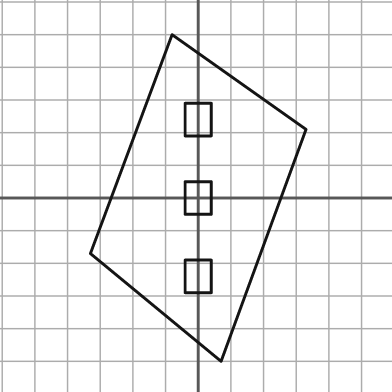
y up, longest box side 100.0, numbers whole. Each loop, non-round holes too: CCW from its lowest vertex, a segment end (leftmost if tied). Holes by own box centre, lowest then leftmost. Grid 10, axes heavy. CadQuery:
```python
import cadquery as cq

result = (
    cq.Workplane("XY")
    .moveTo(7.0, -50.0)
    .lineTo(33.0, 21.0)
    .lineTo(-8.0, 50.0)
    .lineTo(-33.0, -17.0)
    .close()
    .moveTo(-4.0, -29.0)
    .lineTo(4.0, -29.0)
    .lineTo(4.0, -19.0)
    .lineTo(-4.0, -19.0)
    .close()
    .moveTo(-4.0, -5.0)
    .lineTo(4.0, -5.0)
    .lineTo(4.0, 5.0)
    .lineTo(-4.0, 5.0)
    .close()
    .moveTo(-4.0, 19.0)
    .lineTo(4.0, 19.0)
    .lineTo(4.0, 29.0)
    .lineTo(-4.0, 29.0)
    .close()
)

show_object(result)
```